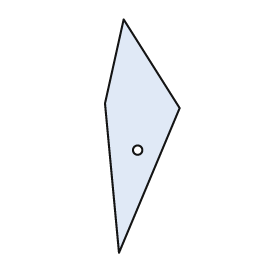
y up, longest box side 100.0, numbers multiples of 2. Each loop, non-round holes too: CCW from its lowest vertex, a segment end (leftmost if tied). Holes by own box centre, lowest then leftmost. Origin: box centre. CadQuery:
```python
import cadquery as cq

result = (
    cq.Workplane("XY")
    .moveTo(-10.0, -50.0)
    .lineTo(16.0, 12.0)
    .lineTo(-8.0, 50.0)
    .lineTo(-16.0, 14.0)
    .close()
    .moveTo(-2.0, -6.0)
    .circle(2.0)
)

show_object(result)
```